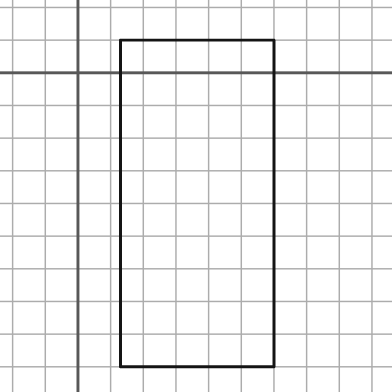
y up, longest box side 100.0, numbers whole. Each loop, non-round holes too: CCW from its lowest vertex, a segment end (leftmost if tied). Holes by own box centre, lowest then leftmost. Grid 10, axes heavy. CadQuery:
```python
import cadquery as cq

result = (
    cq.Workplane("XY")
    .moveTo(13.0, -90.0)
    .lineTo(60.0, -90.0)
    .lineTo(60.0, 10.0)
    .lineTo(13.0, 10.0)
    .close()
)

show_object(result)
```